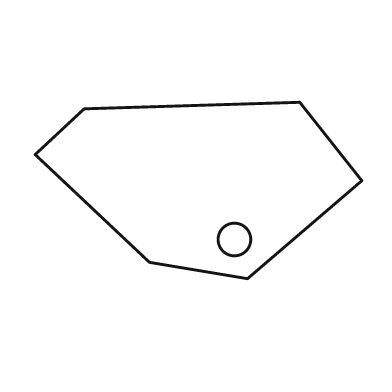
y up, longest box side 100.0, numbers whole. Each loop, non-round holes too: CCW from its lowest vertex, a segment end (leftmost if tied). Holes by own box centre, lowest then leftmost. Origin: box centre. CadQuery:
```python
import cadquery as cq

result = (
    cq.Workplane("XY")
    .moveTo(15.0, -27.0)
    .lineTo(50.0, 3.0)
    .lineTo(31.0, 27.0)
    .lineTo(-35.0, 25.0)
    .lineTo(-50.0, 11.0)
    .lineTo(-15.0, -22.0)
    .close()
    .moveTo(11.0, -15.0)
    .circle(5.0)
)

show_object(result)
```